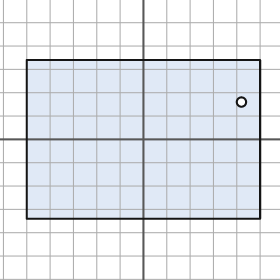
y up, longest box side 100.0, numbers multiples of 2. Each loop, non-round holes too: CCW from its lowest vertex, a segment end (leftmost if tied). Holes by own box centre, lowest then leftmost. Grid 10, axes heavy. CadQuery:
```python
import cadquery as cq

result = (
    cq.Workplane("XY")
    .moveTo(-50.0, -34.0)
    .lineTo(50.0, -34.0)
    .lineTo(50.0, 34.0)
    .lineTo(-50.0, 34.0)
    .close()
    .moveTo(42.0, 16.0)
    .circle(2.0)
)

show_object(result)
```